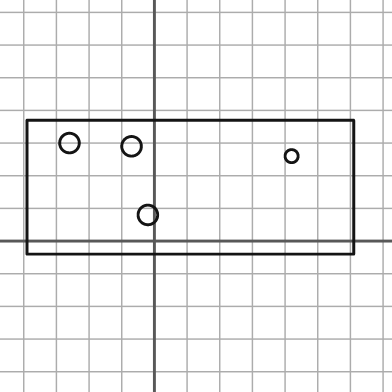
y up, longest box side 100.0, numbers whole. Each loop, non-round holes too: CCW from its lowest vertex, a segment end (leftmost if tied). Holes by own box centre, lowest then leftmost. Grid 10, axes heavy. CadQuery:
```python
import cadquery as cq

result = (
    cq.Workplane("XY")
    .moveTo(-39.0, -4.0)
    .lineTo(61.0, -4.0)
    .lineTo(61.0, 37.0)
    .lineTo(-39.0, 37.0)
    .close()
    .moveTo(-2.0, 8.0)
    .circle(3.0)
    .moveTo(42.0, 26.0)
    .circle(2.0)
    .moveTo(-7.0, 29.0)
    .circle(3.0)
    .moveTo(-26.0, 30.0)
    .circle(3.0)
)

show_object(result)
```